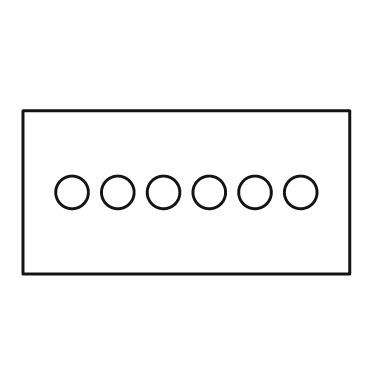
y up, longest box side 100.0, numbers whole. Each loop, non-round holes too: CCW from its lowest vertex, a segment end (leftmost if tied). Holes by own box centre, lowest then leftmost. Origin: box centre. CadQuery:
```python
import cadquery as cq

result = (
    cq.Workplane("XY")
    .moveTo(-50.0, -25.0)
    .lineTo(50.0, -25.0)
    .lineTo(50.0, 25.0)
    .lineTo(-50.0, 25.0)
    .close()
    .moveTo(-35.0, 0.0)
    .circle(5.0)
    .moveTo(-21.0, 0.0)
    .circle(5.0)
    .moveTo(-7.0, 0.0)
    .circle(5.0)
    .moveTo(7.0, 0.0)
    .circle(5.0)
    .moveTo(21.0, 0.0)
    .circle(5.0)
    .moveTo(35.0, 0.0)
    .circle(5.0)
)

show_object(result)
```